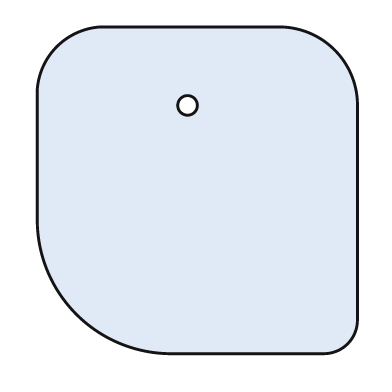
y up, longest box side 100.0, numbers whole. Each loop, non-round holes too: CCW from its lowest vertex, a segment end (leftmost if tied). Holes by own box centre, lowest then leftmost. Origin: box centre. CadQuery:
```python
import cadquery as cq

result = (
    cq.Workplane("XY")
    .moveTo(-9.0, -50.0)
    .lineTo(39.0, -50.0)
    .threePointArc((46.0, -47.0), (49.0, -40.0))
    .lineTo(49.0, 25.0)
    .threePointArc((42.0, 43.0), (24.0, 50.0))
    .lineTo(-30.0, 50.0)
    .threePointArc((-43.0, 44.0), (-49.0, 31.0))
    .lineTo(-49.0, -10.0)
    .threePointArc((-37.0, -38.0), (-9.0, -50.0))
    .close()
    .moveTo(-3.0, 26.0)
    .circle(3.0)
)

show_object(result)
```